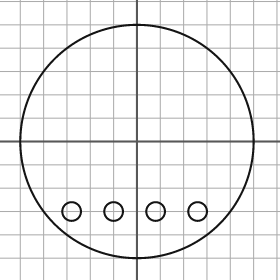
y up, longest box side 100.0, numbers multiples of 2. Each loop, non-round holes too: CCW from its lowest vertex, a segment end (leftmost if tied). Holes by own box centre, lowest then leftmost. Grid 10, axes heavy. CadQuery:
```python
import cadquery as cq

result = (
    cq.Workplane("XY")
    .moveTo(0.0, 0.0)
    .circle(50.0)
    .moveTo(-28.0, -30.0)
    .circle(4.0)
    .moveTo(-10.0, -30.0)
    .circle(4.0)
    .moveTo(8.0, -30.0)
    .circle(4.0)
    .moveTo(26.0, -30.0)
    .circle(4.0)
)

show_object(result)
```